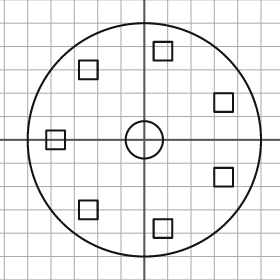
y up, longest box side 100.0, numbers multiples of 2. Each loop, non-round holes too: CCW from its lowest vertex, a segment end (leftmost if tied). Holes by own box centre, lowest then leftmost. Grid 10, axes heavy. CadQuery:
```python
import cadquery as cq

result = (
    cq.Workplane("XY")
    .moveTo(0.0, 0.0)
    .circle(50.0)
    .moveTo(4.0, -42.0)
    .lineTo(12.0, -42.0)
    .lineTo(12.0, -34.0)
    .lineTo(4.0, -34.0)
    .close()
    .moveTo(-28.0, -34.0)
    .lineTo(-20.0, -34.0)
    .lineTo(-20.0, -26.0)
    .lineTo(-28.0, -26.0)
    .close()
    .moveTo(30.0, -20.0)
    .lineTo(38.0, -20.0)
    .lineTo(38.0, -12.0)
    .lineTo(30.0, -12.0)
    .close()
    .moveTo(-42.0, -4.0)
    .lineTo(-34.0, -4.0)
    .lineTo(-34.0, 4.0)
    .lineTo(-42.0, 4.0)
    .close()
    .moveTo(0.0, 0.0)
    .circle(8.0)
    .moveTo(30.0, 12.0)
    .lineTo(38.0, 12.0)
    .lineTo(38.0, 20.0)
    .lineTo(30.0, 20.0)
    .close()
    .moveTo(-28.0, 26.0)
    .lineTo(-20.0, 26.0)
    .lineTo(-20.0, 34.0)
    .lineTo(-28.0, 34.0)
    .close()
    .moveTo(4.0, 34.0)
    .lineTo(12.0, 34.0)
    .lineTo(12.0, 42.0)
    .lineTo(4.0, 42.0)
    .close()
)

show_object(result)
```